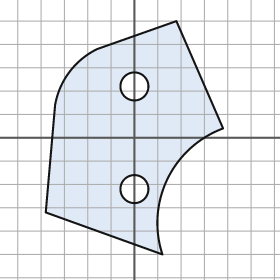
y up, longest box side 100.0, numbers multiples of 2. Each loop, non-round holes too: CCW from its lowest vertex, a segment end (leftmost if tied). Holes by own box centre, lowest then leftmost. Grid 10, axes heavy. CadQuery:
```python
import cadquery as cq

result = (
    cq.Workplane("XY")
    .moveTo(12.0, -50.0)
    .threePointArc((14.0, -18.0), (38.0, 4.0))
    .lineTo(18.0, 50.0)
    .lineTo(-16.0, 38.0)
    .threePointArc((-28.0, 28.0), (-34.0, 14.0))
    .lineTo(-38.0, -32.0)
    .close()
    .moveTo(0.0, -22.0)
    .circle(6.0)
    .moveTo(0.0, 22.0)
    .circle(6.0)
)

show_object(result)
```